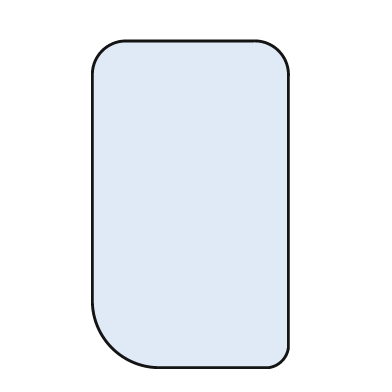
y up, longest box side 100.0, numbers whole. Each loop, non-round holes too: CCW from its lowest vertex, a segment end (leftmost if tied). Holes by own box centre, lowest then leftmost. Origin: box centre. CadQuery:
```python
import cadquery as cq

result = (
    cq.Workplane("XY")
    .moveTo(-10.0, -50.0)
    .lineTo(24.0, -50.0)
    .threePointArc((28.0, -48.0), (30.0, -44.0))
    .lineTo(30.0, 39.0)
    .threePointArc((27.0, 47.0), (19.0, 50.0))
    .lineTo(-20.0, 50.0)
    .threePointArc((-27.0, 47.0), (-30.0, 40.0))
    .lineTo(-30.0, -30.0)
    .threePointArc((-24.0, -44.0), (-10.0, -50.0))
    .close()
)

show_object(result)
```